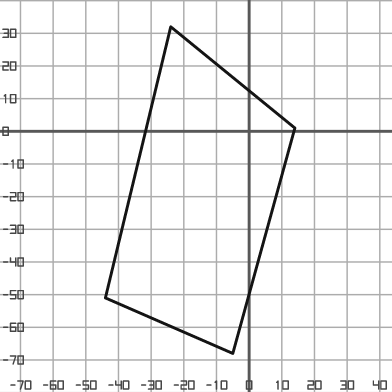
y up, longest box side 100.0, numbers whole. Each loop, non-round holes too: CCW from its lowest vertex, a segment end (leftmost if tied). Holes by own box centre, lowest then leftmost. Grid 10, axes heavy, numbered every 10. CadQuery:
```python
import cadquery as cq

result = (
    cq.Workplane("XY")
    .moveTo(-5.0, -68.0)
    .lineTo(14.0, 1.0)
    .lineTo(-24.0, 32.0)
    .lineTo(-44.0, -51.0)
    .close()
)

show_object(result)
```